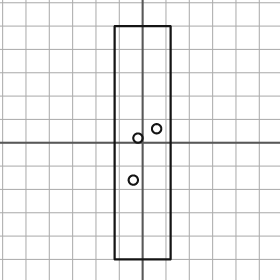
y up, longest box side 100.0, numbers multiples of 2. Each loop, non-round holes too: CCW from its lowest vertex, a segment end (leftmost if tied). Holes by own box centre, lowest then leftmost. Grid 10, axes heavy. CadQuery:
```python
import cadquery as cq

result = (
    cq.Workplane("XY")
    .moveTo(-12.0, -50.0)
    .lineTo(12.0, -50.0)
    .lineTo(12.0, 50.0)
    .lineTo(-12.0, 50.0)
    .close()
    .moveTo(-4.0, -16.0)
    .circle(2.0)
    .moveTo(-2.0, 2.0)
    .circle(2.0)
    .moveTo(6.0, 6.0)
    .circle(2.0)
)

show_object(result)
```